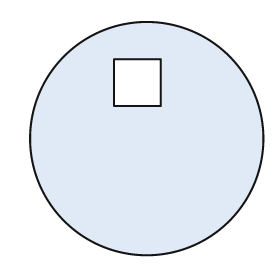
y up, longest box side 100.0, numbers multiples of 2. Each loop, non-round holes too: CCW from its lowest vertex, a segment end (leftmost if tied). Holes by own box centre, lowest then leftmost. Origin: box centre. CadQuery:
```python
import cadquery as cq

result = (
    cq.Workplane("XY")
    .moveTo(0.0, 0.0)
    .circle(50.0)
    .moveTo(-14.0, 14.0)
    .lineTo(6.0, 14.0)
    .lineTo(6.0, 34.0)
    .lineTo(-14.0, 34.0)
    .close()
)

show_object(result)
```